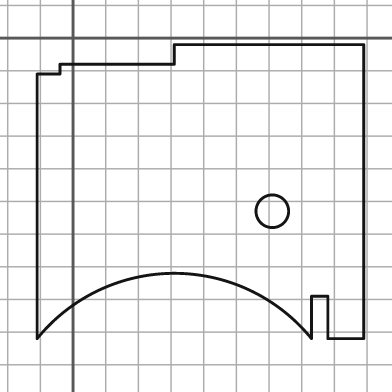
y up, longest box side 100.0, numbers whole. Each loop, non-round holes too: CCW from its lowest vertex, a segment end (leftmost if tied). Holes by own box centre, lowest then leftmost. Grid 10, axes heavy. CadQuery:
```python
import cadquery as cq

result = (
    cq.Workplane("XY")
    .moveTo(-11.0, -92.0)
    .threePointArc((31.0, -72.0), (73.0, -92.0))
    .lineTo(73.0, -79.0)
    .lineTo(78.0, -79.0)
    .lineTo(78.0, -92.0)
    .lineTo(89.0, -92.0)
    .lineTo(89.0, -2.0)
    .lineTo(31.0, -2.0)
    .lineTo(31.0, -8.0)
    .lineTo(-4.0, -8.0)
    .lineTo(-4.0, -11.0)
    .lineTo(-11.0, -11.0)
    .close()
    .moveTo(61.0, -53.0)
    .circle(5.0)
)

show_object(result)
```